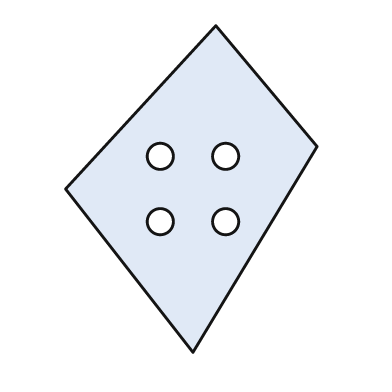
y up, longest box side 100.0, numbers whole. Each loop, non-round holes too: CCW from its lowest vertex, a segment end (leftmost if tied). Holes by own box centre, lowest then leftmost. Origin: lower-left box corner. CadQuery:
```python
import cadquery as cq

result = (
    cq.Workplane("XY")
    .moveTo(39.0, 0.0)
    .lineTo(77.0, 63.0)
    .lineTo(46.0, 100.0)
    .lineTo(0.0, 50.0)
    .close()
    .moveTo(29.0, 40.0)
    .circle(4.0)
    .moveTo(49.0, 40.0)
    .circle(4.0)
    .moveTo(29.0, 60.0)
    .circle(4.0)
    .moveTo(49.0, 60.0)
    .circle(4.0)
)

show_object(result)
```